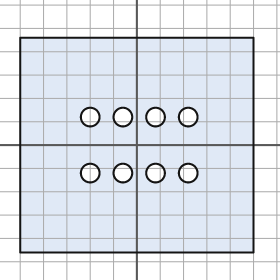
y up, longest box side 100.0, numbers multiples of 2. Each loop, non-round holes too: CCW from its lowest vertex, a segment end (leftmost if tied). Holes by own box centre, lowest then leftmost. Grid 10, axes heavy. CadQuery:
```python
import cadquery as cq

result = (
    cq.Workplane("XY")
    .moveTo(-50.0, -46.0)
    .lineTo(50.0, -46.0)
    .lineTo(50.0, 46.0)
    .lineTo(-50.0, 46.0)
    .close()
    .moveTo(-20.0, -12.0)
    .circle(4.0)
    .moveTo(-6.0, -12.0)
    .circle(4.0)
    .moveTo(8.0, -12.0)
    .circle(4.0)
    .moveTo(22.0, -12.0)
    .circle(4.0)
    .moveTo(-20.0, 12.0)
    .circle(4.0)
    .moveTo(-6.0, 12.0)
    .circle(4.0)
    .moveTo(8.0, 12.0)
    .circle(4.0)
    .moveTo(22.0, 12.0)
    .circle(4.0)
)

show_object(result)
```